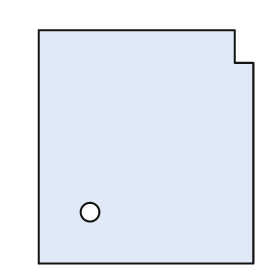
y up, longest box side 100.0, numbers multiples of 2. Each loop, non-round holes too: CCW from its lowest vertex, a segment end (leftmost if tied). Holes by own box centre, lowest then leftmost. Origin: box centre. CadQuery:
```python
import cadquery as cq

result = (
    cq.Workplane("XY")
    .moveTo(-46.0, -50.0)
    .lineTo(46.0, -50.0)
    .lineTo(46.0, 36.0)
    .lineTo(38.0, 36.0)
    .lineTo(38.0, 50.0)
    .lineTo(-46.0, 50.0)
    .close()
    .moveTo(-24.0, -28.0)
    .circle(4.0)
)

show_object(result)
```